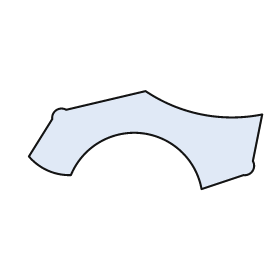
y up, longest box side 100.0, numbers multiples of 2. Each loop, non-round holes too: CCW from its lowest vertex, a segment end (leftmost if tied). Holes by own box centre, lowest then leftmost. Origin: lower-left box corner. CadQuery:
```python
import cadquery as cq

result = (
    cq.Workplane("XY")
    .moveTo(74.0, 0.0)
    .lineTo(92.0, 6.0)
    .threePointArc((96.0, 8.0), (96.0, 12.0))
    .lineTo(100.0, 32.0)
    .threePointArc((74.0, 32.0), (50.0, 42.0))
    .lineTo(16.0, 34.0)
    .threePointArc((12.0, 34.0), (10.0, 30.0))
    .lineTo(0.0, 14.0)
    .threePointArc((8.0, 8.0), (18.0, 6.0))
    .threePointArc((48.0, 24.0), (74.0, 0.0))
    .close()
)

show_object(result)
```